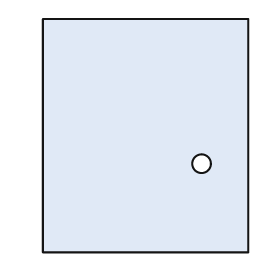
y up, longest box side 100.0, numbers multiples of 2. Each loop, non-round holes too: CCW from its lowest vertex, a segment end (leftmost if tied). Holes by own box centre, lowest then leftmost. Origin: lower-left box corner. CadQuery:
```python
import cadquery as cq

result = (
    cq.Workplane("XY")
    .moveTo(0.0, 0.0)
    .lineTo(88.0, 0.0)
    .lineTo(88.0, 100.0)
    .lineTo(0.0, 100.0)
    .close()
    .moveTo(68.0, 38.0)
    .circle(4.0)
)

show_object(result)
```